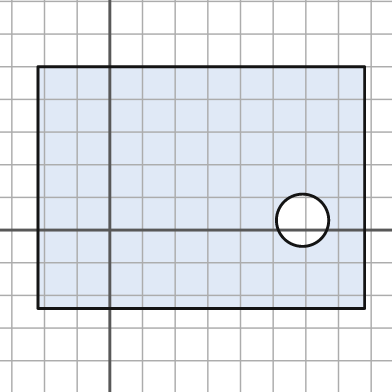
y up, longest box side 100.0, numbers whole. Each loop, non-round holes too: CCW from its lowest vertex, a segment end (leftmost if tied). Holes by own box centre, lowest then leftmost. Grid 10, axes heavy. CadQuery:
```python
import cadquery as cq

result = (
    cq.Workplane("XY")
    .moveTo(-22.0, -24.0)
    .lineTo(78.0, -24.0)
    .lineTo(78.0, 50.0)
    .lineTo(-22.0, 50.0)
    .close()
    .moveTo(59.0, 3.0)
    .circle(8.0)
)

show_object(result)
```